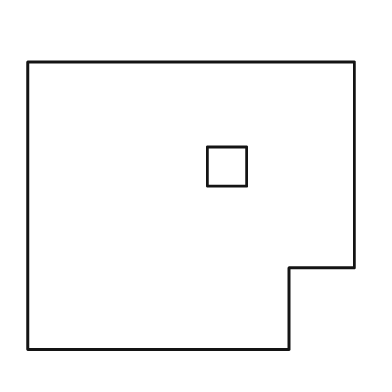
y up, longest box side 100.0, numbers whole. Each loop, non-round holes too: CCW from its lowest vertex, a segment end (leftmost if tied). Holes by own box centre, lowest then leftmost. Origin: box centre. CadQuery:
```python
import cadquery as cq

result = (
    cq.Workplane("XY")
    .moveTo(-50.0, -44.0)
    .lineTo(30.0, -44.0)
    .lineTo(30.0, -19.0)
    .lineTo(50.0, -19.0)
    .lineTo(50.0, 44.0)
    .lineTo(-50.0, 44.0)
    .close()
    .moveTo(5.0, 6.0)
    .lineTo(17.0, 6.0)
    .lineTo(17.0, 18.0)
    .lineTo(5.0, 18.0)
    .close()
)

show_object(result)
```